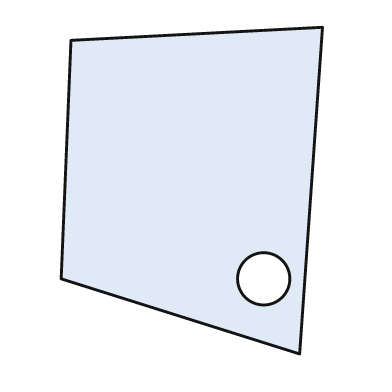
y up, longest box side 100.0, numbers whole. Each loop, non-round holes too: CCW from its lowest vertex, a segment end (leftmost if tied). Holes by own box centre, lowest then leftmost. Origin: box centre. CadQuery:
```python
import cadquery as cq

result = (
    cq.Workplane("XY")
    .moveTo(33.0, -50.0)
    .lineTo(40.0, 50.0)
    .lineTo(-37.0, 46.0)
    .lineTo(-40.0, -27.0)
    .close()
    .moveTo(22.0, -27.0)
    .circle(8.0)
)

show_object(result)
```